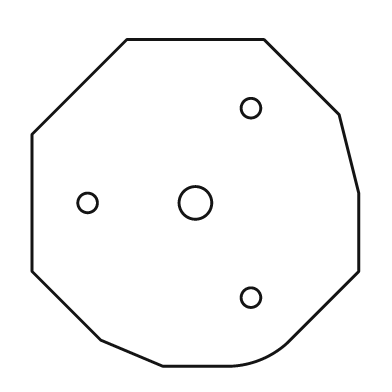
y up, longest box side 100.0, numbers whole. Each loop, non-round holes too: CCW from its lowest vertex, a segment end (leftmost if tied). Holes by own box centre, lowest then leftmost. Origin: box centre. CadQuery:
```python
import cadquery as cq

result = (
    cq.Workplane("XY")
    .moveTo(-10.0, -50.0)
    .lineTo(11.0, -50.0)
    .threePointArc((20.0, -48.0), (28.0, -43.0))
    .lineTo(50.0, -21.0)
    .lineTo(50.0, 3.0)
    .lineTo(44.0, 27.0)
    .lineTo(21.0, 50.0)
    .lineTo(-21.0, 50.0)
    .lineTo(-50.0, 21.0)
    .lineTo(-50.0, -21.0)
    .lineTo(-29.0, -42.0)
    .close()
    .moveTo(17.0, -29.0)
    .circle(3.0)
    .moveTo(-33.0, 0.0)
    .circle(3.0)
    .moveTo(0.0, 0.0)
    .circle(5.0)
    .moveTo(17.0, 29.0)
    .circle(3.0)
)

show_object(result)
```